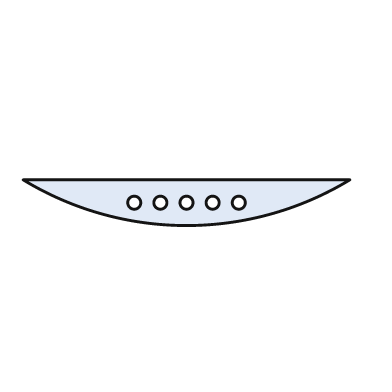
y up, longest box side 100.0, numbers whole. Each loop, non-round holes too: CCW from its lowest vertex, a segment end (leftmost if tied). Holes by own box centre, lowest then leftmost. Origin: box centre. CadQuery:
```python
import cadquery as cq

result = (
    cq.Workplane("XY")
    .moveTo(-50.0, 7.0)
    .threePointArc((0.0, -7.0), (50.0, 7.0))
    .close()
    .moveTo(-16.0, 0.0)
    .circle(2.0)
    .moveTo(-8.0, 0.0)
    .circle(2.0)
    .moveTo(0.0, 0.0)
    .circle(2.0)
    .moveTo(8.0, 0.0)
    .circle(2.0)
    .moveTo(16.0, 0.0)
    .circle(2.0)
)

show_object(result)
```